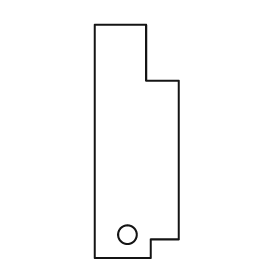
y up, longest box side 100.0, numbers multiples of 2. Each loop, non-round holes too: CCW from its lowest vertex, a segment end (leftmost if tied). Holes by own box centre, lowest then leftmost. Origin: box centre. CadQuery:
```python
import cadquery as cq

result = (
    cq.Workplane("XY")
    .moveTo(-18.0, -50.0)
    .lineTo(6.0, -50.0)
    .lineTo(6.0, -42.0)
    .lineTo(18.0, -42.0)
    .lineTo(18.0, 26.0)
    .lineTo(4.0, 26.0)
    .lineTo(4.0, 50.0)
    .lineTo(-18.0, 50.0)
    .close()
    .moveTo(-4.0, -40.0)
    .circle(4.0)
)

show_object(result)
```